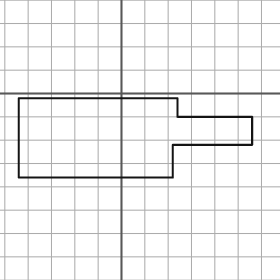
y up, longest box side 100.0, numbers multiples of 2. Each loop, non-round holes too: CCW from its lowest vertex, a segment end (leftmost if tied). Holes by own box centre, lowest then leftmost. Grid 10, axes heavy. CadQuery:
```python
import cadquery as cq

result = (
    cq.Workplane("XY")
    .moveTo(-44.0, -36.0)
    .lineTo(22.0, -36.0)
    .lineTo(22.0, -22.0)
    .lineTo(56.0, -22.0)
    .lineTo(56.0, -10.0)
    .lineTo(24.0, -10.0)
    .lineTo(24.0, -2.0)
    .lineTo(-44.0, -2.0)
    .close()
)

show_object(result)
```